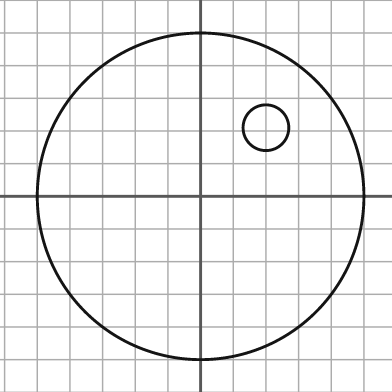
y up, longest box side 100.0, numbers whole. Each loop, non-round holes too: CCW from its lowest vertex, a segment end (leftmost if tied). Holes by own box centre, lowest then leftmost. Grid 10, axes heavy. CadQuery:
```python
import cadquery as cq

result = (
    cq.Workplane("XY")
    .moveTo(0.0, 0.0)
    .circle(50.0)
    .moveTo(20.0, 21.0)
    .circle(7.0)
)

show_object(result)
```